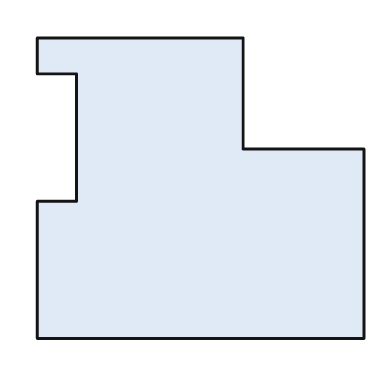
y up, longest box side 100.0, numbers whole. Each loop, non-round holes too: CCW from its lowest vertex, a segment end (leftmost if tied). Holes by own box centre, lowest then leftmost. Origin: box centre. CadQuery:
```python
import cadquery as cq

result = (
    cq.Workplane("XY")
    .moveTo(-50.0, -46.0)
    .lineTo(50.0, -46.0)
    .lineTo(50.0, 12.0)
    .lineTo(13.0, 12.0)
    .lineTo(13.0, 46.0)
    .lineTo(-50.0, 46.0)
    .lineTo(-50.0, 35.0)
    .lineTo(-38.0, 35.0)
    .lineTo(-38.0, -4.0)
    .lineTo(-50.0, -4.0)
    .close()
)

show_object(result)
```